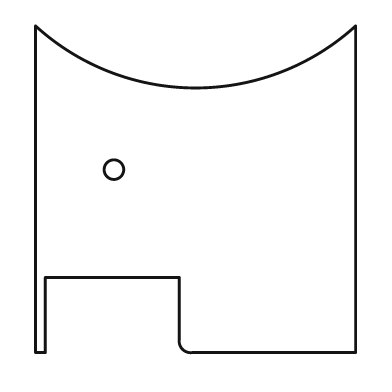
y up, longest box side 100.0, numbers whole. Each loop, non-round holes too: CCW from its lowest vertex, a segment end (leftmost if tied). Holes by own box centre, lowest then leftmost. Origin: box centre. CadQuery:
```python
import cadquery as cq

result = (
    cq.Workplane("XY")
    .moveTo(-49.0, -50.0)
    .lineTo(-46.0, -50.0)
    .lineTo(-46.0, -27.0)
    .lineTo(-5.0, -27.0)
    .lineTo(-5.0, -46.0)
    .threePointArc((-4.0, -49.0), (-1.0, -50.0))
    .lineTo(49.0, -50.0)
    .lineTo(49.0, 50.0)
    .threePointArc((0.0, 31.0), (-49.0, 50.0))
    .close()
    .moveTo(-25.0, 6.0)
    .circle(3.0)
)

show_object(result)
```